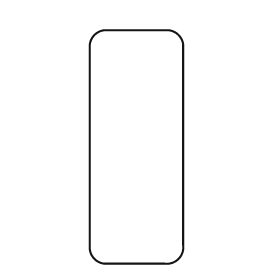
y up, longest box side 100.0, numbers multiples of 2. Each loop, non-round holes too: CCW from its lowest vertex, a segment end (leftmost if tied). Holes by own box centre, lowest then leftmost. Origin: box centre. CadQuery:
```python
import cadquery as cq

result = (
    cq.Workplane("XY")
    .moveTo(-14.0, -50.0)
    .lineTo(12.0, -50.0)
    .threePointArc((18.0, -48.0), (20.0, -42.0))
    .lineTo(20.0, 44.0)
    .threePointArc((18.0, 48.0), (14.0, 50.0))
    .lineTo(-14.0, 50.0)
    .threePointArc((-18.0, 48.0), (-20.0, 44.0))
    .lineTo(-20.0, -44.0)
    .threePointArc((-18.0, -48.0), (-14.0, -50.0))
    .close()
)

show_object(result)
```